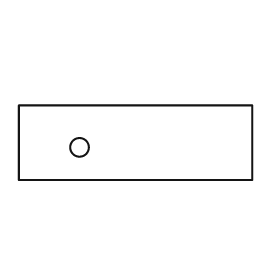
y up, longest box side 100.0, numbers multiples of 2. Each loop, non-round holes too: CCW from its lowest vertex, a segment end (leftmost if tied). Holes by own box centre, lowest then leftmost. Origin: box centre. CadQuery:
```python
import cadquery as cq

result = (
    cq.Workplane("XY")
    .moveTo(-50.0, -16.0)
    .lineTo(50.0, -16.0)
    .lineTo(50.0, 16.0)
    .lineTo(-50.0, 16.0)
    .close()
    .moveTo(-24.0, -2.0)
    .circle(4.0)
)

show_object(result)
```